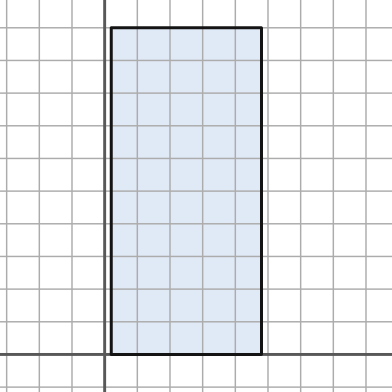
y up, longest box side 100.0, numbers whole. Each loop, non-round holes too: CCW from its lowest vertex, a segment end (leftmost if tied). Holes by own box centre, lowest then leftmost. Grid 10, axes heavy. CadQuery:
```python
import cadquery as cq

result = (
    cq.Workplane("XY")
    .moveTo(2.0, 0.0)
    .lineTo(48.0, 0.0)
    .lineTo(48.0, 100.0)
    .lineTo(2.0, 100.0)
    .close()
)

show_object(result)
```